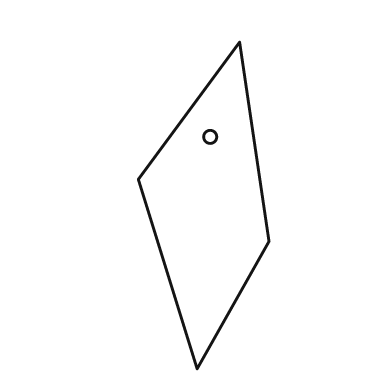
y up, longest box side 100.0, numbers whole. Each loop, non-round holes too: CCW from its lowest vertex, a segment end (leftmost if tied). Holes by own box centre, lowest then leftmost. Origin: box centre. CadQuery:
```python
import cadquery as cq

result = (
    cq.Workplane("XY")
    .moveTo(-2.0, -50.0)
    .lineTo(20.0, -11.0)
    .lineTo(11.0, 50.0)
    .lineTo(-20.0, 8.0)
    .close()
    .moveTo(2.0, 21.0)
    .circle(2.0)
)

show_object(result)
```